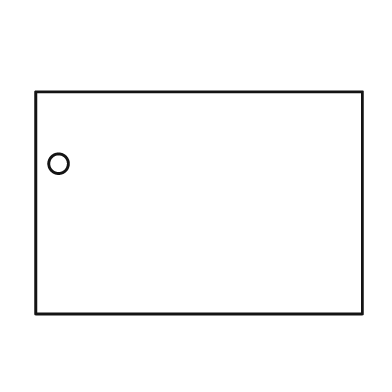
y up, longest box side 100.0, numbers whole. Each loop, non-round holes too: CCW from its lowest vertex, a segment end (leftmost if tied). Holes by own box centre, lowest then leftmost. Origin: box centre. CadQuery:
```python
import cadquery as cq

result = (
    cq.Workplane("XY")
    .moveTo(-50.0, -34.0)
    .lineTo(50.0, -34.0)
    .lineTo(50.0, 34.0)
    .lineTo(-50.0, 34.0)
    .close()
    .moveTo(-43.0, 12.0)
    .circle(3.0)
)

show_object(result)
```